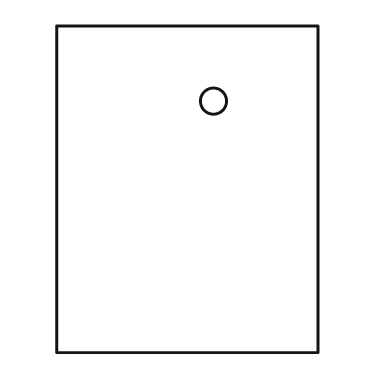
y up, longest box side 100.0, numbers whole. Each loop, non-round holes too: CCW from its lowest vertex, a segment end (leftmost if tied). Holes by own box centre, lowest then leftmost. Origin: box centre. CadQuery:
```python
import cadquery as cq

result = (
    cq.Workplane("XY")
    .moveTo(-40.0, -50.0)
    .lineTo(40.0, -50.0)
    .lineTo(40.0, 50.0)
    .lineTo(-40.0, 50.0)
    .close()
    .moveTo(8.0, 27.0)
    .circle(4.0)
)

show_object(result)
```